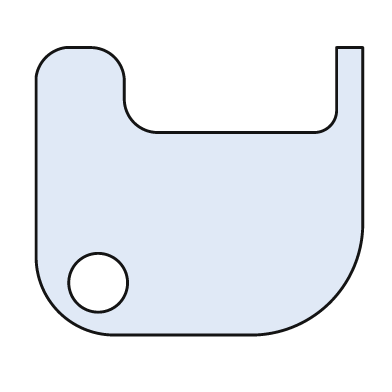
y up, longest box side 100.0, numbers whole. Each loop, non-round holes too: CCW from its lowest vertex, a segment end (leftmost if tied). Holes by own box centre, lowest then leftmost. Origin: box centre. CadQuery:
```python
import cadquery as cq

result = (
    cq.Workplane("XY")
    .moveTo(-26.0, -44.0)
    .lineTo(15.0, -44.0)
    .threePointArc((40.0, -34.0), (50.0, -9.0))
    .lineTo(50.0, 44.0)
    .lineTo(42.0, 44.0)
    .lineTo(42.0, 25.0)
    .threePointArc((40.0, 20.0), (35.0, 18.0))
    .lineTo(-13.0, 18.0)
    .threePointArc((-20.0, 21.0), (-23.0, 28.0))
    .lineTo(-23.0, 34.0)
    .threePointArc((-26.0, 41.0), (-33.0, 44.0))
    .lineTo(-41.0, 44.0)
    .threePointArc((-47.0, 41.0), (-50.0, 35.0))
    .lineTo(-50.0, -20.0)
    .threePointArc((-43.0, -37.0), (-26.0, -44.0))
    .close()
    .moveTo(-31.0, -28.0)
    .circle(9.0)
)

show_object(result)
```